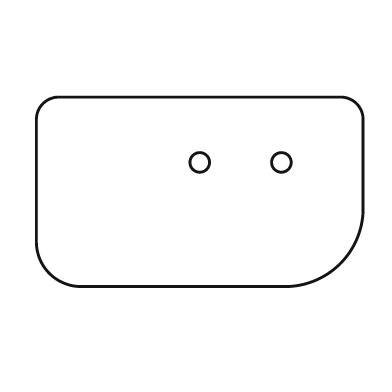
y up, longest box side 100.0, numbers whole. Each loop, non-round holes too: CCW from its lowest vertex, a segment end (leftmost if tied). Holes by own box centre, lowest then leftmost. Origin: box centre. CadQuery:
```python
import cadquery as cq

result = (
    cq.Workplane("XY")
    .moveTo(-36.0, -29.0)
    .lineTo(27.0, -29.0)
    .threePointArc((43.0, -22.0), (50.0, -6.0))
    .lineTo(50.0, 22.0)
    .threePointArc((48.0, 27.0), (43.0, 29.0))
    .lineTo(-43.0, 29.0)
    .threePointArc((-48.0, 27.0), (-50.0, 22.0))
    .lineTo(-50.0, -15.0)
    .threePointArc((-46.0, -25.0), (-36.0, -29.0))
    .close()
    .moveTo(0.0, 9.0)
    .circle(3.0)
    .moveTo(25.0, 9.0)
    .circle(3.0)
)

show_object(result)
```